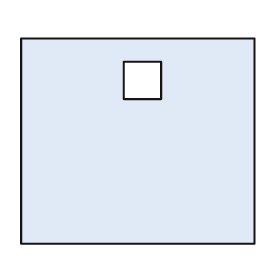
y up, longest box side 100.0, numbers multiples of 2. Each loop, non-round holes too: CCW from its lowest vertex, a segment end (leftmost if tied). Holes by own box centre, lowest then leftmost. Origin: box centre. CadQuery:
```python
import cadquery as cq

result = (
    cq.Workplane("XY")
    .moveTo(-50.0, -44.0)
    .lineTo(50.0, -44.0)
    .lineTo(50.0, 44.0)
    .lineTo(-50.0, 44.0)
    .close()
    .moveTo(-6.0, 18.0)
    .lineTo(10.0, 18.0)
    .lineTo(10.0, 34.0)
    .lineTo(-6.0, 34.0)
    .close()
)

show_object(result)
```